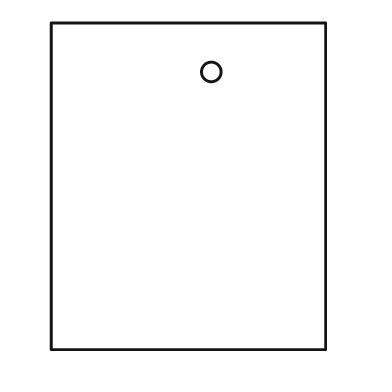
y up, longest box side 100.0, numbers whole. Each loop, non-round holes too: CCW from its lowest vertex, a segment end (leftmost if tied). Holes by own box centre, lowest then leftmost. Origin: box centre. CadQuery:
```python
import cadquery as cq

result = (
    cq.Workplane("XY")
    .moveTo(-42.0, -50.0)
    .lineTo(42.0, -50.0)
    .lineTo(42.0, 50.0)
    .lineTo(-42.0, 50.0)
    .close()
    .moveTo(7.0, 35.0)
    .circle(3.0)
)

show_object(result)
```